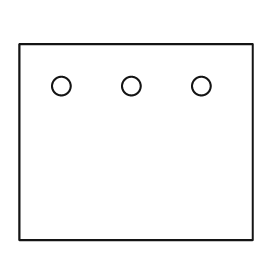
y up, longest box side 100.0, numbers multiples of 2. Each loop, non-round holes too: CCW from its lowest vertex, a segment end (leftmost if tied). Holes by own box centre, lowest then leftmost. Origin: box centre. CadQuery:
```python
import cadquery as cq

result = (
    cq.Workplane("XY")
    .moveTo(-50.0, -42.0)
    .lineTo(50.0, -42.0)
    .lineTo(50.0, 42.0)
    .lineTo(-50.0, 42.0)
    .close()
    .moveTo(-32.0, 24.0)
    .circle(4.0)
    .moveTo(-2.0, 24.0)
    .circle(4.0)
    .moveTo(28.0, 24.0)
    .circle(4.0)
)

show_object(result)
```